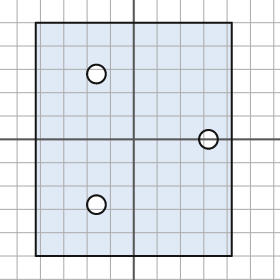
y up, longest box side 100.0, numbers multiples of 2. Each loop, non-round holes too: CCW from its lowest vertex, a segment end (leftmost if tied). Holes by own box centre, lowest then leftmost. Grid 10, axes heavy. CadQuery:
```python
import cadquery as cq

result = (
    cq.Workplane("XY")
    .moveTo(-42.0, -50.0)
    .lineTo(42.0, -50.0)
    .lineTo(42.0, 50.0)
    .lineTo(-42.0, 50.0)
    .close()
    .moveTo(-16.0, -28.0)
    .circle(4.0)
    .moveTo(32.0, 0.0)
    .circle(4.0)
    .moveTo(-16.0, 28.0)
    .circle(4.0)
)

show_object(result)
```